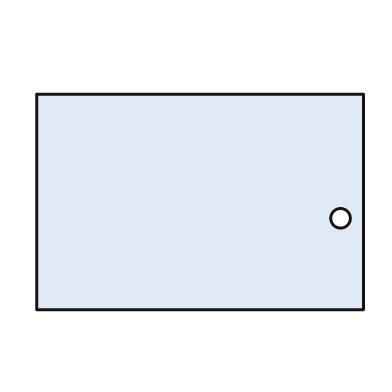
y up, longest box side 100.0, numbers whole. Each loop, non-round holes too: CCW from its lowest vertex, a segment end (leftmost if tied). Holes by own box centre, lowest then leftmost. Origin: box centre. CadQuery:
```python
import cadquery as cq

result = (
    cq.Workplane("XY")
    .moveTo(-50.0, -33.0)
    .lineTo(50.0, -33.0)
    .lineTo(50.0, 33.0)
    .lineTo(-50.0, 33.0)
    .close()
    .moveTo(43.0, -5.0)
    .circle(3.0)
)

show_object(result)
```